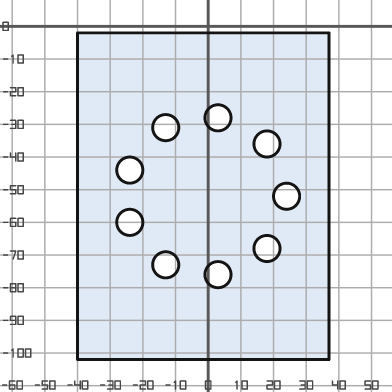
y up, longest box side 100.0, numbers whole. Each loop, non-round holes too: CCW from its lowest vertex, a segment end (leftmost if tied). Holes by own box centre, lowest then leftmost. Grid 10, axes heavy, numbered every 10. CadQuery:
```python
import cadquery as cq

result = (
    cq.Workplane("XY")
    .moveTo(-40.0, -102.0)
    .lineTo(37.0, -102.0)
    .lineTo(37.0, -2.0)
    .lineTo(-40.0, -2.0)
    .close()
    .moveTo(3.0, -76.0)
    .circle(4.0)
    .moveTo(-13.0, -73.0)
    .circle(4.0)
    .moveTo(18.0, -68.0)
    .circle(4.0)
    .moveTo(-24.0, -60.0)
    .circle(4.0)
    .moveTo(24.0, -52.0)
    .circle(4.0)
    .moveTo(-24.0, -44.0)
    .circle(4.0)
    .moveTo(18.0, -36.0)
    .circle(4.0)
    .moveTo(-13.0, -31.0)
    .circle(4.0)
    .moveTo(3.0, -28.0)
    .circle(4.0)
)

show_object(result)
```